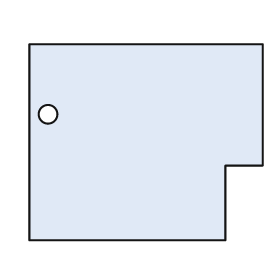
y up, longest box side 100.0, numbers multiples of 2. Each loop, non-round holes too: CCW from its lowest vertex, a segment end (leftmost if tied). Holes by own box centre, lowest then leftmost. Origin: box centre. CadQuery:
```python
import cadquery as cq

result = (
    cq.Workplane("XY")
    .moveTo(-50.0, -42.0)
    .lineTo(34.0, -42.0)
    .lineTo(34.0, -10.0)
    .lineTo(50.0, -10.0)
    .lineTo(50.0, 42.0)
    .lineTo(-50.0, 42.0)
    .close()
    .moveTo(-42.0, 12.0)
    .circle(4.0)
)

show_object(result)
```